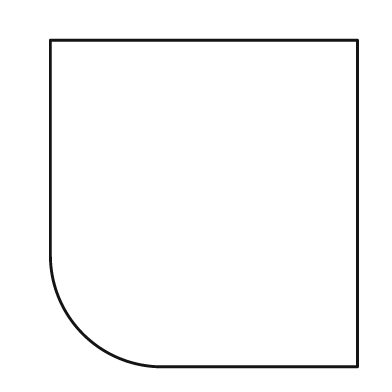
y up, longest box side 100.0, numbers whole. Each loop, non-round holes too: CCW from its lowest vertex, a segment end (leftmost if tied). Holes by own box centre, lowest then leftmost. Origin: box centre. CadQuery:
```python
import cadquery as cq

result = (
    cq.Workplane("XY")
    .moveTo(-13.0, -50.0)
    .lineTo(47.0, -50.0)
    .lineTo(47.0, 50.0)
    .lineTo(-47.0, 50.0)
    .lineTo(-47.0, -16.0)
    .threePointArc((-37.0, -40.0), (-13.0, -50.0))
    .close()
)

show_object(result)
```